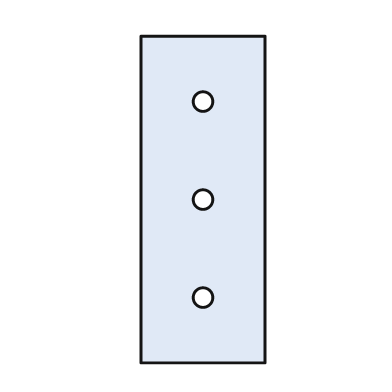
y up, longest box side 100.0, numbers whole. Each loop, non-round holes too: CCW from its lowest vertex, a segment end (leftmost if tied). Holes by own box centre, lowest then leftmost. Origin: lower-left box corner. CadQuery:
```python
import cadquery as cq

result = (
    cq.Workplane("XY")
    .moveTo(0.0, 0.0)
    .lineTo(38.0, 0.0)
    .lineTo(38.0, 100.0)
    .lineTo(0.0, 100.0)
    .close()
    .moveTo(19.0, 20.0)
    .circle(3.0)
    .moveTo(19.0, 50.0)
    .circle(3.0)
    .moveTo(19.0, 80.0)
    .circle(3.0)
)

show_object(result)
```